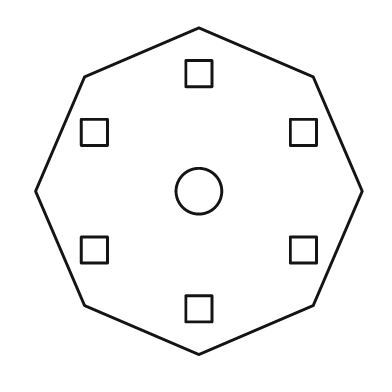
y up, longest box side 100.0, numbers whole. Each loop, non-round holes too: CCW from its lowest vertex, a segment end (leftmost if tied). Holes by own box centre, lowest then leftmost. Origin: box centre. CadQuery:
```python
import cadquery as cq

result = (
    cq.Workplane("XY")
    .moveTo(0.0, -50.0)
    .lineTo(35.0, -35.0)
    .lineTo(50.0, 0.0)
    .lineTo(35.0, 35.0)
    .lineTo(0.0, 50.0)
    .lineTo(-35.0, 35.0)
    .lineTo(-50.0, 0.0)
    .lineTo(-35.0, -35.0)
    .close()
    .moveTo(-4.0, -40.0)
    .lineTo(4.0, -40.0)
    .lineTo(4.0, -32.0)
    .lineTo(-4.0, -32.0)
    .close()
    .moveTo(-36.0, -22.0)
    .lineTo(-28.0, -22.0)
    .lineTo(-28.0, -14.0)
    .lineTo(-36.0, -14.0)
    .close()
    .moveTo(28.0, -22.0)
    .lineTo(36.0, -22.0)
    .lineTo(36.0, -14.0)
    .lineTo(28.0, -14.0)
    .close()
    .moveTo(0.0, 0.0)
    .circle(7.0)
    .moveTo(-36.0, 14.0)
    .lineTo(-28.0, 14.0)
    .lineTo(-28.0, 22.0)
    .lineTo(-36.0, 22.0)
    .close()
    .moveTo(28.0, 14.0)
    .lineTo(36.0, 14.0)
    .lineTo(36.0, 22.0)
    .lineTo(28.0, 22.0)
    .close()
    .moveTo(-4.0, 32.0)
    .lineTo(4.0, 32.0)
    .lineTo(4.0, 40.0)
    .lineTo(-4.0, 40.0)
    .close()
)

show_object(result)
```